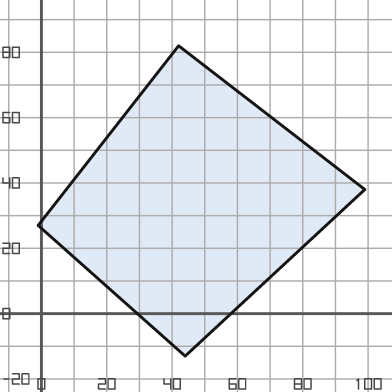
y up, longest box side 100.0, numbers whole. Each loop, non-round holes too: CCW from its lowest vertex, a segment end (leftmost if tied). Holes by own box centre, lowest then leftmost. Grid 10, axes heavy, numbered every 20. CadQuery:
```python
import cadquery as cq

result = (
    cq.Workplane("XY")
    .moveTo(44.0, -13.0)
    .lineTo(99.0, 38.0)
    .lineTo(42.0, 82.0)
    .lineTo(-1.0, 27.0)
    .close()
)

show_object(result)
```